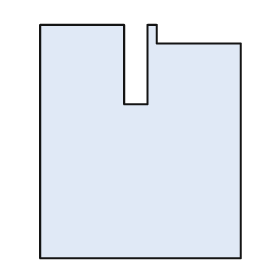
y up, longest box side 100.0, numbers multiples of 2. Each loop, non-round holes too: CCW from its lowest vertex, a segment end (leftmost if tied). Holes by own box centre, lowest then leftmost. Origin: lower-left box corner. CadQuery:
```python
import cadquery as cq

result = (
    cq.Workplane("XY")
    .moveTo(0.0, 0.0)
    .lineTo(86.0, 0.0)
    .lineTo(86.0, 92.0)
    .lineTo(50.0, 92.0)
    .lineTo(50.0, 100.0)
    .lineTo(46.0, 100.0)
    .lineTo(46.0, 66.0)
    .lineTo(36.0, 66.0)
    .lineTo(36.0, 100.0)
    .lineTo(0.0, 100.0)
    .close()
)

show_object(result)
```